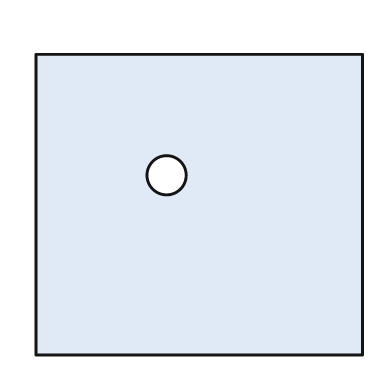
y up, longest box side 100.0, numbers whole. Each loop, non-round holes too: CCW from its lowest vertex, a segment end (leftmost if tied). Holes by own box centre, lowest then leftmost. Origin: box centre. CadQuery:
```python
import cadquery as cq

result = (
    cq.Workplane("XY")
    .moveTo(-50.0, -46.0)
    .lineTo(50.0, -46.0)
    .lineTo(50.0, 46.0)
    .lineTo(-50.0, 46.0)
    .close()
    .moveTo(-10.0, 9.0)
    .circle(6.0)
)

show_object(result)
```